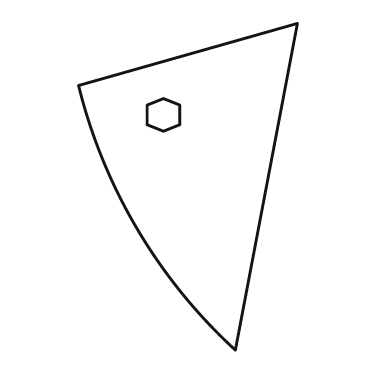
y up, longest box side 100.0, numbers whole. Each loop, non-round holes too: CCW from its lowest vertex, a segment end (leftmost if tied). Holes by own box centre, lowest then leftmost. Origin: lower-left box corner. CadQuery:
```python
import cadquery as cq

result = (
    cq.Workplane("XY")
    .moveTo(48.0, 0.0)
    .lineTo(67.0, 100.0)
    .lineTo(0.0, 81.0)
    .threePointArc((18.0, 37.0), (48.0, 0.0))
    .close()
    .moveTo(26.0, 67.0)
    .lineTo(31.0, 69.0)
    .lineTo(31.0, 75.0)
    .lineTo(26.0, 77.0)
    .lineTo(21.0, 75.0)
    .lineTo(21.0, 69.0)
    .close()
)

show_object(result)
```